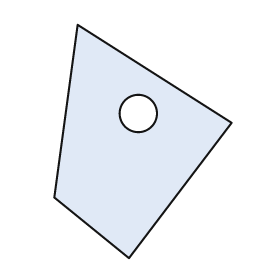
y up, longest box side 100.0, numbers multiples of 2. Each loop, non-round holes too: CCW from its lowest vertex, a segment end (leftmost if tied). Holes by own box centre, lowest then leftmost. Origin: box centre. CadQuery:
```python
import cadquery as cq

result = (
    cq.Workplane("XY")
    .moveTo(-6.0, -50.0)
    .lineTo(38.0, 8.0)
    .lineTo(-28.0, 50.0)
    .lineTo(-38.0, -24.0)
    .close()
    .moveTo(-2.0, 12.0)
    .circle(8.0)
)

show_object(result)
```